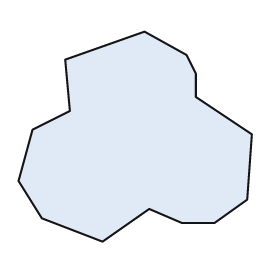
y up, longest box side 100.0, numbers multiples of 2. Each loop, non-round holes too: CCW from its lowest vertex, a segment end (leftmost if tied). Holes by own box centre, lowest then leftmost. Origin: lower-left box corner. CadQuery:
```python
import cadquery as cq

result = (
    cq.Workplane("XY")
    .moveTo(36.0, 0.0)
    .lineTo(56.0, 14.0)
    .lineTo(70.0, 8.0)
    .lineTo(84.0, 8.0)
    .lineTo(98.0, 18.0)
    .lineTo(100.0, 46.0)
    .lineTo(76.0, 62.0)
    .lineTo(76.0, 72.0)
    .lineTo(72.0, 80.0)
    .lineTo(54.0, 90.0)
    .lineTo(20.0, 78.0)
    .lineTo(22.0, 56.0)
    .lineTo(6.0, 48.0)
    .lineTo(0.0, 26.0)
    .lineTo(10.0, 10.0)
    .close()
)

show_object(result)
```